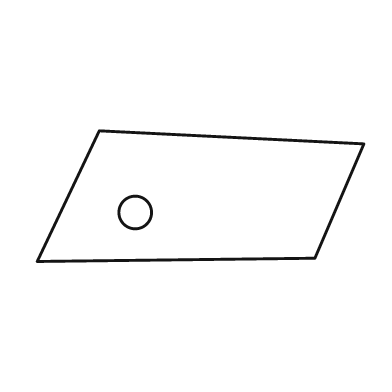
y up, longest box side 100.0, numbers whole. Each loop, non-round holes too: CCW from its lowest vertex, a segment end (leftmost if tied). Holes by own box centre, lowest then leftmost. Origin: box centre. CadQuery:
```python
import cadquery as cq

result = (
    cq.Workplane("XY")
    .moveTo(-50.0, -20.0)
    .lineTo(35.0, -19.0)
    .lineTo(50.0, 16.0)
    .lineTo(-31.0, 20.0)
    .close()
    .moveTo(-20.0, -5.0)
    .circle(5.0)
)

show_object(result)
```